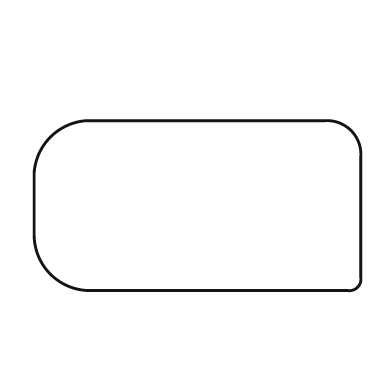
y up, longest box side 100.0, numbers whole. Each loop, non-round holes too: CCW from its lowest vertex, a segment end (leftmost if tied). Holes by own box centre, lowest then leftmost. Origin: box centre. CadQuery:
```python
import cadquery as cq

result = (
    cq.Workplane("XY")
    .moveTo(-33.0, -26.0)
    .lineTo(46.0, -26.0)
    .threePointArc((49.0, -25.0), (50.0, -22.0))
    .lineTo(50.0, 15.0)
    .threePointArc((47.0, 23.0), (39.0, 26.0))
    .lineTo(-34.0, 26.0)
    .threePointArc((-45.0, 21.0), (-50.0, 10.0))
    .lineTo(-50.0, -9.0)
    .threePointArc((-45.0, -21.0), (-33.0, -26.0))
    .close()
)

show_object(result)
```